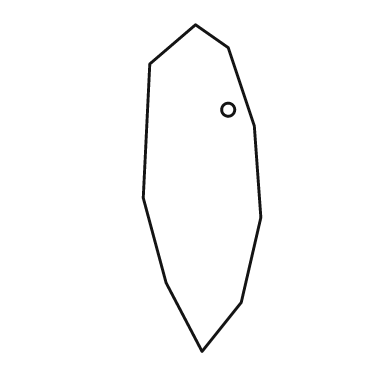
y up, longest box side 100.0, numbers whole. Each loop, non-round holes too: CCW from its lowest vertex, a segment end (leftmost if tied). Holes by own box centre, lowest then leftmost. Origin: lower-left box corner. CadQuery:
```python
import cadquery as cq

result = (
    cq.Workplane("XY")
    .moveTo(18.0, 0.0)
    .lineTo(30.0, 15.0)
    .lineTo(36.0, 41.0)
    .lineTo(34.0, 69.0)
    .lineTo(26.0, 93.0)
    .lineTo(16.0, 100.0)
    .lineTo(2.0, 88.0)
    .lineTo(0.0, 47.0)
    .lineTo(7.0, 21.0)
    .close()
    .moveTo(26.0, 74.0)
    .circle(2.0)
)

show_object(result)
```